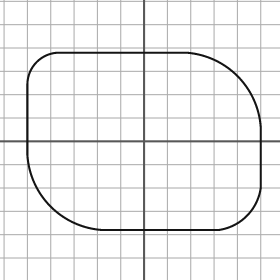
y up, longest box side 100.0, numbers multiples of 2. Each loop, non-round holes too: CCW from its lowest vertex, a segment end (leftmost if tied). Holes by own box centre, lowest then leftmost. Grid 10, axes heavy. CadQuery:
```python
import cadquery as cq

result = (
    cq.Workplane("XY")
    .moveTo(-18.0, -38.0)
    .lineTo(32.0, -38.0)
    .threePointArc((44.0, -32.0), (50.0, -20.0))
    .lineTo(50.0, 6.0)
    .threePointArc((40.0, 28.0), (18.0, 38.0))
    .lineTo(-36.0, 38.0)
    .threePointArc((-46.0, 34.0), (-50.0, 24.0))
    .lineTo(-50.0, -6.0)
    .threePointArc((-40.0, -28.0), (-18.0, -38.0))
    .close()
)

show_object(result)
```